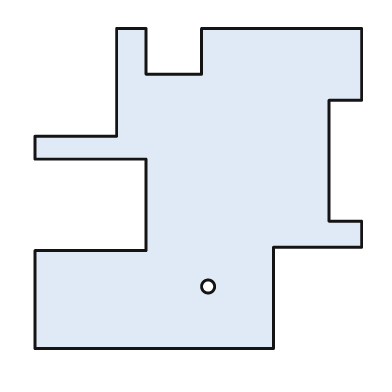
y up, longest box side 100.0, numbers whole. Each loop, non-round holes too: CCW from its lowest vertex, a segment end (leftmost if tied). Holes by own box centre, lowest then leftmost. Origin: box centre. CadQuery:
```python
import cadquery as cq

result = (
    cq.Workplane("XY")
    .moveTo(-50.0, -49.0)
    .lineTo(23.0, -49.0)
    .lineTo(23.0, -18.0)
    .lineTo(50.0, -18.0)
    .lineTo(50.0, -10.0)
    .lineTo(40.0, -10.0)
    .lineTo(40.0, 27.0)
    .lineTo(50.0, 27.0)
    .lineTo(50.0, 49.0)
    .lineTo(1.0, 49.0)
    .lineTo(1.0, 35.0)
    .lineTo(-16.0, 35.0)
    .lineTo(-16.0, 49.0)
    .lineTo(-25.0, 49.0)
    .lineTo(-25.0, 16.0)
    .lineTo(-50.0, 16.0)
    .lineTo(-50.0, 9.0)
    .lineTo(-16.0, 9.0)
    .lineTo(-16.0, -19.0)
    .lineTo(-50.0, -19.0)
    .close()
    .moveTo(3.0, -30.0)
    .circle(2.0)
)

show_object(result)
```